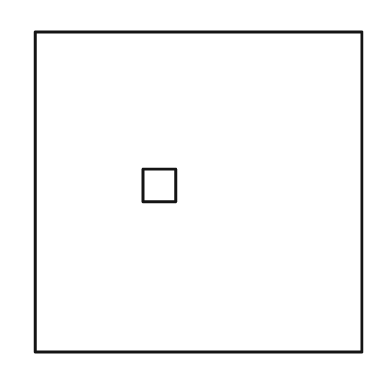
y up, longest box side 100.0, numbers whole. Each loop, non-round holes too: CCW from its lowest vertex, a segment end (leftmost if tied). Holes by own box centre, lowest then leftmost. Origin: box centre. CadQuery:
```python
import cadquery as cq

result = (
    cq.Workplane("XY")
    .moveTo(-50.0, -49.0)
    .lineTo(50.0, -49.0)
    .lineTo(50.0, 49.0)
    .lineTo(-50.0, 49.0)
    .close()
    .moveTo(-17.0, -3.0)
    .lineTo(-7.0, -3.0)
    .lineTo(-7.0, 7.0)
    .lineTo(-17.0, 7.0)
    .close()
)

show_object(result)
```